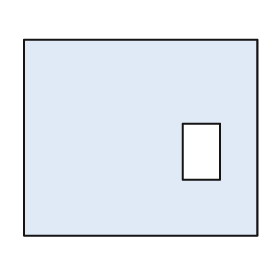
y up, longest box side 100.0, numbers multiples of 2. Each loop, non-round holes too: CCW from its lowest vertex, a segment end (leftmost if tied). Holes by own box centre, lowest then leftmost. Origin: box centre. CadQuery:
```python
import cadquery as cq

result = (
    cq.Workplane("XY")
    .moveTo(-50.0, -42.0)
    .lineTo(50.0, -42.0)
    .lineTo(50.0, 42.0)
    .lineTo(-50.0, 42.0)
    .close()
    .moveTo(18.0, -18.0)
    .lineTo(34.0, -18.0)
    .lineTo(34.0, 6.0)
    .lineTo(18.0, 6.0)
    .close()
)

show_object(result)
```